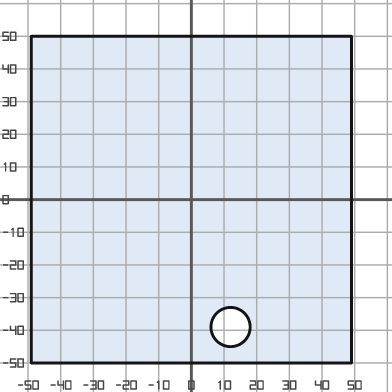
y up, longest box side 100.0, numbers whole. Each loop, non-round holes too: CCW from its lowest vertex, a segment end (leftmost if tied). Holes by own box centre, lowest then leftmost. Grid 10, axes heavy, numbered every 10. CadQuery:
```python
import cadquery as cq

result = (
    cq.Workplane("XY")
    .moveTo(-49.0, -50.0)
    .lineTo(49.0, -50.0)
    .lineTo(49.0, 50.0)
    .lineTo(-49.0, 50.0)
    .close()
    .moveTo(12.0, -39.0)
    .circle(6.0)
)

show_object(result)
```